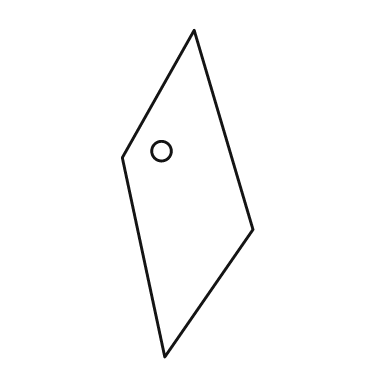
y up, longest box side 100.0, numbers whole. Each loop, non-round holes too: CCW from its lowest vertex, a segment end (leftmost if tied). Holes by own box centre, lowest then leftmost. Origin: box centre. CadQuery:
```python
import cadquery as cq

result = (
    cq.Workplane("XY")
    .moveTo(-7.0, -50.0)
    .lineTo(20.0, -11.0)
    .lineTo(2.0, 50.0)
    .lineTo(-20.0, 11.0)
    .close()
    .moveTo(-8.0, 13.0)
    .circle(3.0)
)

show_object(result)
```